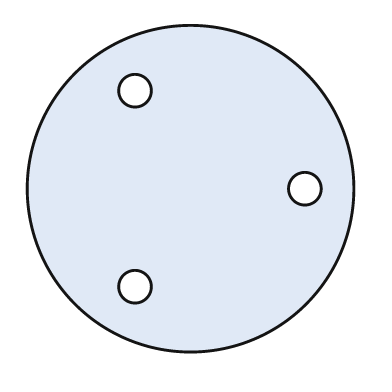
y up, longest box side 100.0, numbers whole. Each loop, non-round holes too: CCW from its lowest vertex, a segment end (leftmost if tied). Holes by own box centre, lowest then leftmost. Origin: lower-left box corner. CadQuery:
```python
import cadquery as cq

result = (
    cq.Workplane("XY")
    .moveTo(50.0, 50.0)
    .circle(50.0)
    .moveTo(33.0, 20.0)
    .circle(5.0)
    .moveTo(85.0, 50.0)
    .circle(5.0)
    .moveTo(33.0, 80.0)
    .circle(5.0)
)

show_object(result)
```